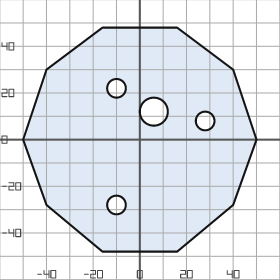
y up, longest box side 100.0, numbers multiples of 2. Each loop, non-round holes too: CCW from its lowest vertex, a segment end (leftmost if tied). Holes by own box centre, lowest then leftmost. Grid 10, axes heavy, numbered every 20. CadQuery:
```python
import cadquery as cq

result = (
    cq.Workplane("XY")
    .moveTo(-16.0, -48.0)
    .lineTo(16.0, -48.0)
    .lineTo(40.0, -28.0)
    .lineTo(50.0, 0.0)
    .lineTo(40.0, 30.0)
    .lineTo(16.0, 48.0)
    .lineTo(-16.0, 48.0)
    .lineTo(-40.0, 30.0)
    .lineTo(-50.0, 0.0)
    .lineTo(-40.0, -28.0)
    .close()
    .moveTo(-10.0, -28.0)
    .circle(4.0)
    .moveTo(28.0, 8.0)
    .circle(4.0)
    .moveTo(6.0, 12.0)
    .circle(6.0)
    .moveTo(-10.0, 22.0)
    .circle(4.0)
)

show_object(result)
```